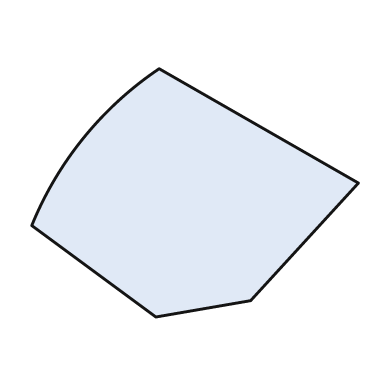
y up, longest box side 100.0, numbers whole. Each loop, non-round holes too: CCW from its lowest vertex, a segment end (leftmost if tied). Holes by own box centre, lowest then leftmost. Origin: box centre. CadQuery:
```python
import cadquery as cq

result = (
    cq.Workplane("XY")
    .moveTo(-12.0, -38.0)
    .lineTo(17.0, -33.0)
    .lineTo(50.0, 3.0)
    .lineTo(-11.0, 38.0)
    .threePointArc((-34.0, 17.0), (-50.0, -10.0))
    .close()
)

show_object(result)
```